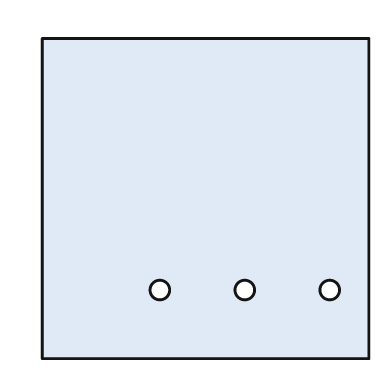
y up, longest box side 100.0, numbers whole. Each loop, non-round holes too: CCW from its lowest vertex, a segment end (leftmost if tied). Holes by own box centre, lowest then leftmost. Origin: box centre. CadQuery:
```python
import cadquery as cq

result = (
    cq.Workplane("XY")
    .moveTo(-50.0, -49.0)
    .lineTo(50.0, -49.0)
    .lineTo(50.0, 49.0)
    .lineTo(-50.0, 49.0)
    .close()
    .moveTo(-14.0, -28.0)
    .circle(3.0)
    .moveTo(12.0, -28.0)
    .circle(3.0)
    .moveTo(38.0, -28.0)
    .circle(3.0)
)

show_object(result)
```